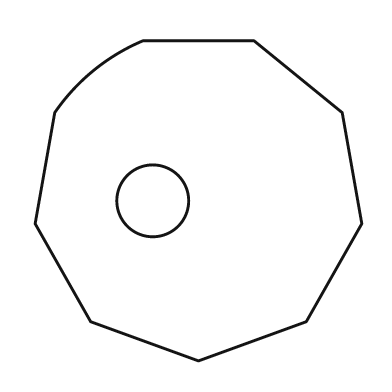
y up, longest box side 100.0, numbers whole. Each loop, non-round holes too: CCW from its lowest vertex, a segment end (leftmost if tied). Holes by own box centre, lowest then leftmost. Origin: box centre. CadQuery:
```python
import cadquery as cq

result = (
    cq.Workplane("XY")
    .moveTo(0.0, -49.0)
    .lineTo(33.0, -37.0)
    .lineTo(50.0, -7.0)
    .lineTo(44.0, 27.0)
    .lineTo(17.0, 49.0)
    .lineTo(-17.0, 49.0)
    .threePointArc((-32.0, 40.0), (-44.0, 27.0))
    .lineTo(-50.0, -7.0)
    .lineTo(-33.0, -37.0)
    .close()
    .moveTo(-14.0, 0.0)
    .circle(11.0)
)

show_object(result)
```